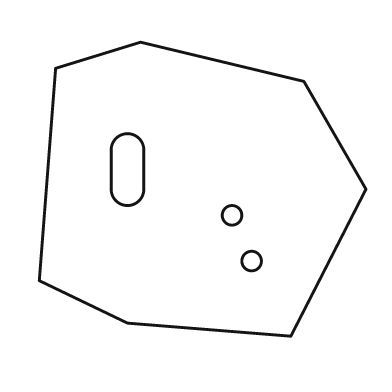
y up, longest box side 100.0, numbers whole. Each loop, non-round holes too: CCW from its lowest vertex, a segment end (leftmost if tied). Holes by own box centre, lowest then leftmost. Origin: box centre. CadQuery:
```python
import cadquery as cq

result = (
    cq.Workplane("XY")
    .moveTo(27.0, -45.0)
    .lineTo(50.0, 0.0)
    .lineTo(31.0, 33.0)
    .lineTo(-19.0, 45.0)
    .lineTo(-45.0, 37.0)
    .lineTo(-50.0, -28.0)
    .lineTo(-23.0, -41.0)
    .close()
    .moveTo(15.0, -22.0)
    .circle(3.0)
    .moveTo(9.0, -8.0)
    .circle(3.0)
    .moveTo(-28.0, 0.0)
    .threePointArc((-23.0, -5.0), (-18.0, 0.0))
    .lineTo(-18.0, 12.0)
    .threePointArc((-23.0, 17.0), (-28.0, 12.0))
    .close()
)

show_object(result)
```